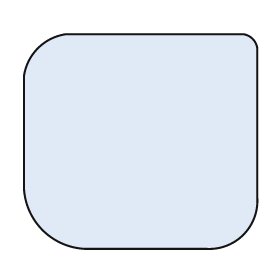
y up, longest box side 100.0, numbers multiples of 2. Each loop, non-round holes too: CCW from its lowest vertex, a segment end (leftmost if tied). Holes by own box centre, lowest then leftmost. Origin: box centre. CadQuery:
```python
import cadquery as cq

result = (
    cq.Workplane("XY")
    .moveTo(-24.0, -46.0)
    .lineTo(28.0, -46.0)
    .threePointArc((44.0, -40.0), (50.0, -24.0))
    .lineTo(50.0, 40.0)
    .threePointArc((48.0, 44.0), (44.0, 46.0))
    .lineTo(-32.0, 46.0)
    .threePointArc((-44.0, 40.0), (-50.0, 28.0))
    .lineTo(-50.0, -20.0)
    .threePointArc((-42.0, -38.0), (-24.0, -46.0))
    .close()
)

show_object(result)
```